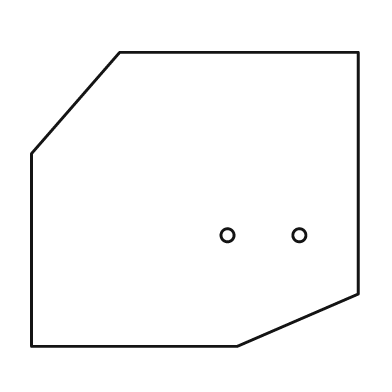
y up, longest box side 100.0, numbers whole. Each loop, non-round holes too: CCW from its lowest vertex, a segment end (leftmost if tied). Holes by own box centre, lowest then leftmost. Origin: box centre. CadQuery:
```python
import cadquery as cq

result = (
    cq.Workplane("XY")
    .moveTo(-50.0, -45.0)
    .lineTo(13.0, -45.0)
    .lineTo(50.0, -29.0)
    .lineTo(50.0, 45.0)
    .lineTo(-23.0, 45.0)
    .lineTo(-50.0, 14.0)
    .close()
    .moveTo(10.0, -11.0)
    .circle(2.0)
    .moveTo(32.0, -11.0)
    .circle(2.0)
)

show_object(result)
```